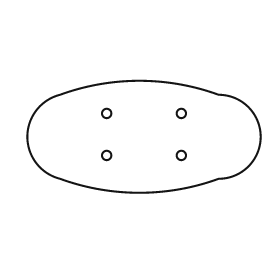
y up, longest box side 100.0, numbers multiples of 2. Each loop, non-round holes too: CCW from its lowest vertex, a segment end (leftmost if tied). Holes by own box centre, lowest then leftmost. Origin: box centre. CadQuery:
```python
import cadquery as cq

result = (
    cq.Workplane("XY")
    .moveTo(-36.0, -18.0)
    .threePointArc((-2.0, -24.0), (32.0, -18.0))
    .threePointArc((50.0, 0.0), (32.0, 18.0))
    .threePointArc((-2.0, 24.0), (-36.0, 18.0))
    .threePointArc((-50.0, 0.0), (-36.0, -18.0))
    .close()
    .moveTo(-16.0, -8.0)
    .circle(2.0)
    .moveTo(16.0, -8.0)
    .circle(2.0)
    .moveTo(-16.0, 10.0)
    .circle(2.0)
    .moveTo(16.0, 10.0)
    .circle(2.0)
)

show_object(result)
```